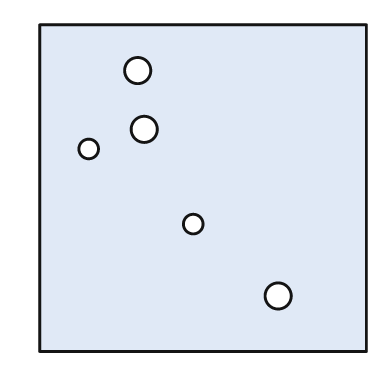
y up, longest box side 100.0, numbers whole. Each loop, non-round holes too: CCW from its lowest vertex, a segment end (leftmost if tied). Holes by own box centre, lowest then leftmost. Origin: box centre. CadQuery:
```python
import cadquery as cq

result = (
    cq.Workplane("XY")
    .moveTo(-50.0, -50.0)
    .lineTo(50.0, -50.0)
    .lineTo(50.0, 50.0)
    .lineTo(-50.0, 50.0)
    .close()
    .moveTo(23.0, -33.0)
    .circle(4.0)
    .moveTo(-3.0, -11.0)
    .circle(3.0)
    .moveTo(-35.0, 12.0)
    .circle(3.0)
    .moveTo(-18.0, 18.0)
    .circle(4.0)
    .moveTo(-20.0, 36.0)
    .circle(4.0)
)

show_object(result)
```